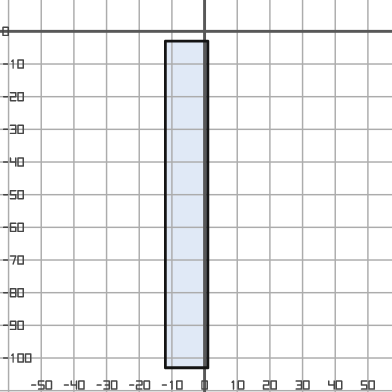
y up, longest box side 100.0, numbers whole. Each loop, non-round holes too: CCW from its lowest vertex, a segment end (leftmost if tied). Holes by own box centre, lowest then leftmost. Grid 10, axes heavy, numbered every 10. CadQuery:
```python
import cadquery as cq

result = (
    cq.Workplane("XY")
    .moveTo(-12.0, -103.0)
    .lineTo(1.0, -103.0)
    .lineTo(1.0, -3.0)
    .lineTo(-12.0, -3.0)
    .close()
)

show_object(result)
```